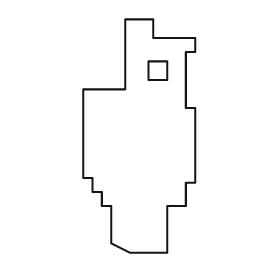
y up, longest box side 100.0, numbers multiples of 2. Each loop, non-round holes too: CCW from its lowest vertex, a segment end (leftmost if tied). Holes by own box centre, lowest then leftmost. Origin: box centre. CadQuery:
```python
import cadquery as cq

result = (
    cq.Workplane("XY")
    .moveTo(-4.0, -50.0)
    .lineTo(12.0, -50.0)
    .lineTo(12.0, -30.0)
    .lineTo(20.0, -30.0)
    .lineTo(20.0, -20.0)
    .lineTo(24.0, -20.0)
    .lineTo(24.0, 12.0)
    .lineTo(20.0, 12.0)
    .lineTo(20.0, 36.0)
    .lineTo(24.0, 36.0)
    .lineTo(24.0, 42.0)
    .lineTo(6.0, 42.0)
    .lineTo(6.0, 50.0)
    .lineTo(-6.0, 50.0)
    .lineTo(-6.0, 20.0)
    .lineTo(-24.0, 20.0)
    .lineTo(-24.0, -18.0)
    .lineTo(-20.0, -18.0)
    .lineTo(-20.0, -24.0)
    .lineTo(-16.0, -24.0)
    .lineTo(-16.0, -30.0)
    .lineTo(-12.0, -30.0)
    .lineTo(-12.0, -46.0)
    .close()
    .moveTo(4.0, 24.0)
    .lineTo(12.0, 24.0)
    .lineTo(12.0, 32.0)
    .lineTo(4.0, 32.0)
    .close()
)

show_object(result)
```